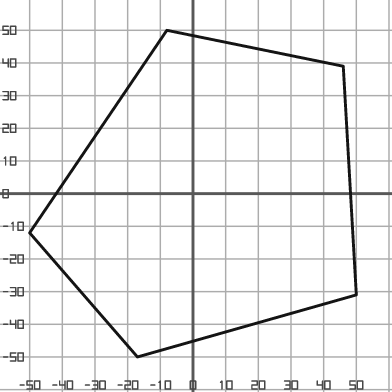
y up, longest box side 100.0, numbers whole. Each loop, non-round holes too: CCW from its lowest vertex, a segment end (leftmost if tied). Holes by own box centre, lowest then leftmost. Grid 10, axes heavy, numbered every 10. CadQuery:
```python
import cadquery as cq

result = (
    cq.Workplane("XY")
    .moveTo(-17.0, -50.0)
    .lineTo(50.0, -31.0)
    .lineTo(46.0, 39.0)
    .lineTo(-8.0, 50.0)
    .lineTo(-50.0, -12.0)
    .close()
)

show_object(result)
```